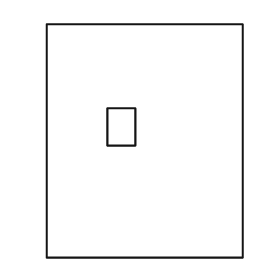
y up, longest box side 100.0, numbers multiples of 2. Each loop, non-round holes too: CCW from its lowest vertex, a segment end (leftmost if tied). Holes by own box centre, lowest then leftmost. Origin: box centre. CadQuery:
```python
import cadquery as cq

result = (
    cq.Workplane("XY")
    .moveTo(-42.0, -50.0)
    .lineTo(42.0, -50.0)
    .lineTo(42.0, 50.0)
    .lineTo(-42.0, 50.0)
    .close()
    .moveTo(-16.0, -2.0)
    .lineTo(-4.0, -2.0)
    .lineTo(-4.0, 14.0)
    .lineTo(-16.0, 14.0)
    .close()
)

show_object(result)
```